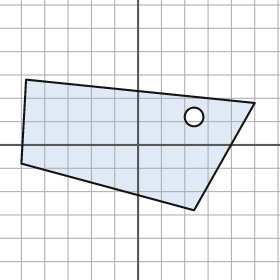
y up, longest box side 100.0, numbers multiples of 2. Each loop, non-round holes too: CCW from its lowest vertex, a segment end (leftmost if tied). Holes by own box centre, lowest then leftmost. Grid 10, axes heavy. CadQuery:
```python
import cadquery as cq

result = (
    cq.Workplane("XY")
    .moveTo(24.0, -28.0)
    .lineTo(50.0, 18.0)
    .lineTo(-48.0, 28.0)
    .lineTo(-50.0, -8.0)
    .close()
    .moveTo(24.0, 12.0)
    .circle(4.0)
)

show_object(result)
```